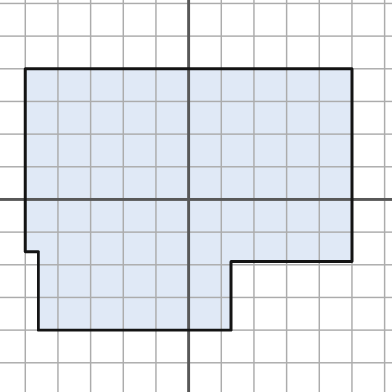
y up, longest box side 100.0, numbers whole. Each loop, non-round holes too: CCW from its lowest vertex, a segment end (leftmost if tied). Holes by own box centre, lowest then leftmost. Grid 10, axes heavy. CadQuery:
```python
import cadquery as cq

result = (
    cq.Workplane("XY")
    .moveTo(-46.0, -40.0)
    .lineTo(13.0, -40.0)
    .lineTo(13.0, -19.0)
    .lineTo(50.0, -19.0)
    .lineTo(50.0, 40.0)
    .lineTo(-50.0, 40.0)
    .lineTo(-50.0, -16.0)
    .lineTo(-46.0, -16.0)
    .close()
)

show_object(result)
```